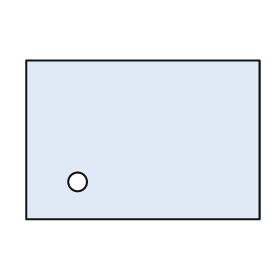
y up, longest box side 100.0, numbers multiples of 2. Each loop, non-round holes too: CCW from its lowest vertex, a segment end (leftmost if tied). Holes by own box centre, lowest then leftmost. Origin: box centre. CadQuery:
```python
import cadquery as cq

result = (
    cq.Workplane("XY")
    .moveTo(-50.0, -34.0)
    .lineTo(50.0, -34.0)
    .lineTo(50.0, 34.0)
    .lineTo(-50.0, 34.0)
    .close()
    .moveTo(-28.0, -18.0)
    .circle(4.0)
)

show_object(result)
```